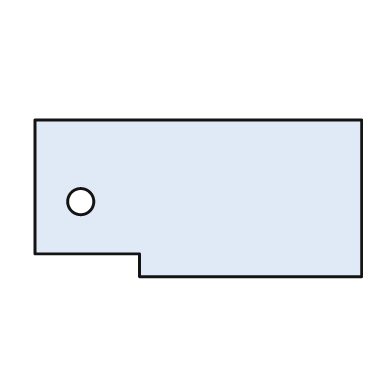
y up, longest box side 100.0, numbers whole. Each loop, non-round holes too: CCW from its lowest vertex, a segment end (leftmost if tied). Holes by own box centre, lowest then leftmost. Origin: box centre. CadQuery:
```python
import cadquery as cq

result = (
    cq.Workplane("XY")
    .moveTo(-18.0, -24.0)
    .lineTo(50.0, -24.0)
    .lineTo(50.0, 24.0)
    .lineTo(-50.0, 24.0)
    .lineTo(-50.0, -17.0)
    .lineTo(-18.0, -17.0)
    .close()
    .moveTo(-36.0, -1.0)
    .circle(4.0)
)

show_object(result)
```